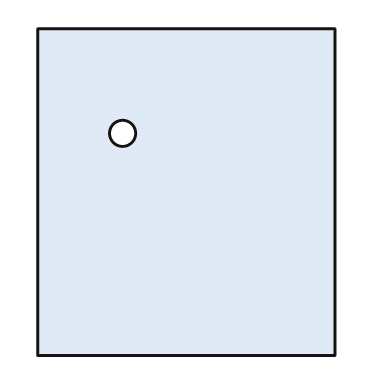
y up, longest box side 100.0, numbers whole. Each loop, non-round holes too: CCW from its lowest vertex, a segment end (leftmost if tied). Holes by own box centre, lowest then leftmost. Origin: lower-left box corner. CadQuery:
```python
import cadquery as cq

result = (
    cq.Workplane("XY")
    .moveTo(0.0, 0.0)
    .lineTo(91.0, 0.0)
    .lineTo(91.0, 100.0)
    .lineTo(0.0, 100.0)
    .close()
    .moveTo(26.0, 68.0)
    .circle(4.0)
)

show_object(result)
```